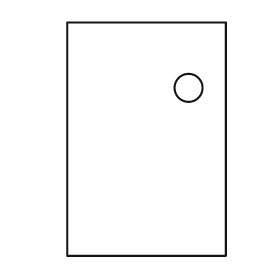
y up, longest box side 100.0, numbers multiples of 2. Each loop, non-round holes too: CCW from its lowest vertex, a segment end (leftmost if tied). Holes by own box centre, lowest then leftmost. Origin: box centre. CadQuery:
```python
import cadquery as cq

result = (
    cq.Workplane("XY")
    .moveTo(-34.0, -50.0)
    .lineTo(34.0, -50.0)
    .lineTo(34.0, 50.0)
    .lineTo(-34.0, 50.0)
    .close()
    .moveTo(18.0, 22.0)
    .circle(6.0)
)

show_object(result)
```